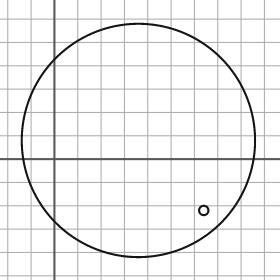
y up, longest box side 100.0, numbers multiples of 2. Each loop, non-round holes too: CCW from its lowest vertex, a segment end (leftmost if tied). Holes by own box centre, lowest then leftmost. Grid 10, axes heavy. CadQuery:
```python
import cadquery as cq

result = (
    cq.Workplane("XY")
    .moveTo(36.0, 8.0)
    .circle(50.0)
    .moveTo(64.0, -22.0)
    .circle(2.0)
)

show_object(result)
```